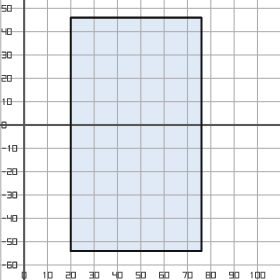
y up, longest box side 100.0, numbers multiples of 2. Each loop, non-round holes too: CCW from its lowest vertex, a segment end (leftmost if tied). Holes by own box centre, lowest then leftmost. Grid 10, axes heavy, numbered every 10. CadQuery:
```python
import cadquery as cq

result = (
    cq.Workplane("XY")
    .moveTo(20.0, -54.0)
    .lineTo(76.0, -54.0)
    .lineTo(76.0, 46.0)
    .lineTo(20.0, 46.0)
    .close()
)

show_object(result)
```